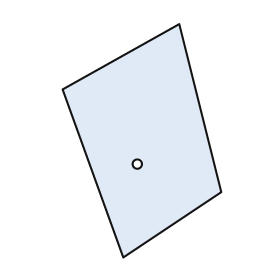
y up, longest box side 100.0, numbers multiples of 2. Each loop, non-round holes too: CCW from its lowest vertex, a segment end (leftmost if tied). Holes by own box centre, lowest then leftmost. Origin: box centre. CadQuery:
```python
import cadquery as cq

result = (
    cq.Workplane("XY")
    .moveTo(-8.0, -50.0)
    .lineTo(34.0, -22.0)
    .lineTo(16.0, 50.0)
    .lineTo(-34.0, 22.0)
    .close()
    .moveTo(-2.0, -10.0)
    .circle(2.0)
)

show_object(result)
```